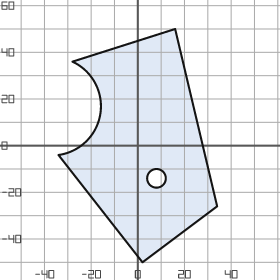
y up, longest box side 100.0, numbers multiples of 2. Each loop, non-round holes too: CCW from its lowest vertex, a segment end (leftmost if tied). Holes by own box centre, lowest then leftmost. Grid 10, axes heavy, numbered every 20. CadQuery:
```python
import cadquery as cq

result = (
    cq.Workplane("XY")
    .moveTo(2.0, -50.0)
    .lineTo(34.0, -26.0)
    .lineTo(16.0, 50.0)
    .lineTo(-28.0, 36.0)
    .threePointArc((-16.0, 14.0), (-34.0, -4.0))
    .close()
    .moveTo(8.0, -14.0)
    .circle(4.0)
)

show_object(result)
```